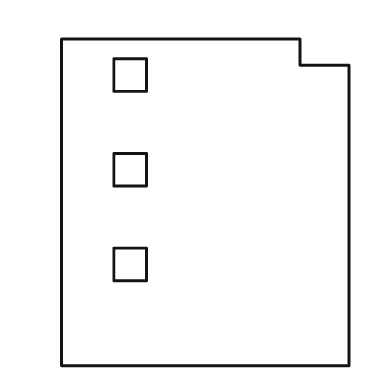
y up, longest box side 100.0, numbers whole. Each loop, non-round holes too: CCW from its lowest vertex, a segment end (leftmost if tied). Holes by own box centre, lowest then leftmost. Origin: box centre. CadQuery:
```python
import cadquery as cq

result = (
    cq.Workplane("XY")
    .moveTo(-44.0, -50.0)
    .lineTo(44.0, -50.0)
    .lineTo(44.0, 42.0)
    .lineTo(29.0, 42.0)
    .lineTo(29.0, 50.0)
    .lineTo(-44.0, 50.0)
    .close()
    .moveTo(-28.0, -24.0)
    .lineTo(-18.0, -24.0)
    .lineTo(-18.0, -14.0)
    .lineTo(-28.0, -14.0)
    .close()
    .moveTo(-28.0, 5.0)
    .lineTo(-18.0, 5.0)
    .lineTo(-18.0, 15.0)
    .lineTo(-28.0, 15.0)
    .close()
    .moveTo(-28.0, 34.0)
    .lineTo(-18.0, 34.0)
    .lineTo(-18.0, 44.0)
    .lineTo(-28.0, 44.0)
    .close()
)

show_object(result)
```